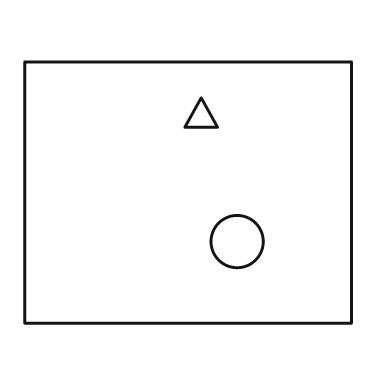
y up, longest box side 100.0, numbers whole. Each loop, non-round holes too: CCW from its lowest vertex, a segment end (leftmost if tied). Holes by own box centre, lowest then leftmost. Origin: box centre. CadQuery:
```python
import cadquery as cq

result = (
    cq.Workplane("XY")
    .moveTo(-50.0, -40.0)
    .lineTo(50.0, -40.0)
    .lineTo(50.0, 40.0)
    .lineTo(-50.0, 40.0)
    .close()
    .moveTo(15.0, -15.0)
    .circle(8.0)
    .moveTo(-1.0, 20.0)
    .lineTo(9.0, 20.0)
    .lineTo(4.0, 29.0)
    .close()
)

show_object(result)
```